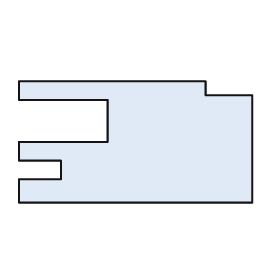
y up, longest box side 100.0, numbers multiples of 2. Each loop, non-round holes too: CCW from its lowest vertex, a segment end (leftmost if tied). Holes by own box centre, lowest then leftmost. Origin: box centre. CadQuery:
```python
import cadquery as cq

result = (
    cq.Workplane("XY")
    .moveTo(-50.0, -26.0)
    .lineTo(50.0, -26.0)
    .lineTo(50.0, 20.0)
    .lineTo(30.0, 20.0)
    .lineTo(30.0, 26.0)
    .lineTo(-50.0, 26.0)
    .lineTo(-50.0, 18.0)
    .lineTo(-12.0, 18.0)
    .lineTo(-12.0, 0.0)
    .lineTo(-50.0, 0.0)
    .lineTo(-50.0, -8.0)
    .lineTo(-32.0, -8.0)
    .lineTo(-32.0, -16.0)
    .lineTo(-50.0, -16.0)
    .close()
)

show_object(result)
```